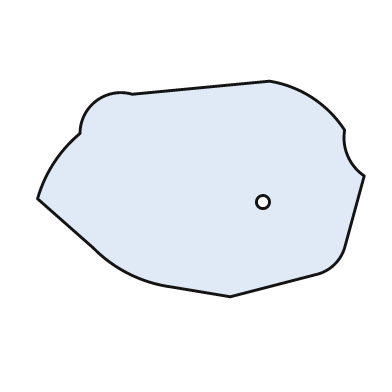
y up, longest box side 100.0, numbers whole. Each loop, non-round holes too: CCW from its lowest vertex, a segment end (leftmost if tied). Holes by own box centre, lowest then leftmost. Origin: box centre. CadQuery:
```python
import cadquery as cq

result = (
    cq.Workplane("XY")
    .moveTo(9.0, -33.0)
    .lineTo(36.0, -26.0)
    .threePointArc((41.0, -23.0), (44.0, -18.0))
    .lineTo(50.0, 4.0)
    .threePointArc((45.0, 10.0), (44.0, 18.0))
    .threePointArc((34.0, 28.0), (21.0, 33.0))
    .lineTo(-21.0, 29.0)
    .threePointArc((-32.0, 27.0), (-37.0, 17.0))
    .threePointArc((-45.0, 8.0), (-50.0, -3.0))
    .lineTo(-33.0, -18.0)
    .threePointArc((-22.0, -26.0), (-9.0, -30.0))
    .close()
    .moveTo(19.0, -4.0)
    .circle(2.0)
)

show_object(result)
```